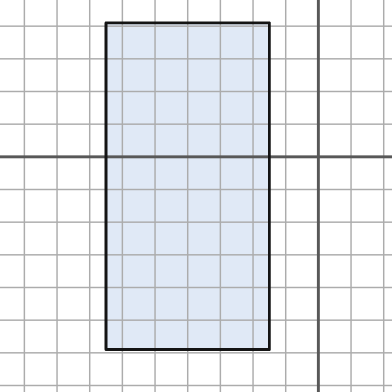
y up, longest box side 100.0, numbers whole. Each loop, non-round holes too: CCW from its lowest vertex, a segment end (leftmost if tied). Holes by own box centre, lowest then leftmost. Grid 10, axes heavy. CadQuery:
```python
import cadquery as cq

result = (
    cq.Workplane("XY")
    .moveTo(-65.0, -59.0)
    .lineTo(-15.0, -59.0)
    .lineTo(-15.0, 41.0)
    .lineTo(-65.0, 41.0)
    .close()
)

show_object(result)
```